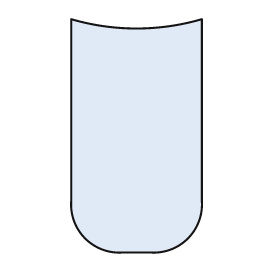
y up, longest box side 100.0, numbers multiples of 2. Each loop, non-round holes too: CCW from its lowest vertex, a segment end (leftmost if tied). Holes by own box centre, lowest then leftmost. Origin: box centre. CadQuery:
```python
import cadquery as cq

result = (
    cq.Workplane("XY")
    .moveTo(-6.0, -50.0)
    .lineTo(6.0, -50.0)
    .threePointArc((22.0, -44.0), (28.0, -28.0))
    .lineTo(28.0, 50.0)
    .threePointArc((0.0, 46.0), (-28.0, 50.0))
    .lineTo(-28.0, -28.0)
    .threePointArc((-22.0, -44.0), (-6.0, -50.0))
    .close()
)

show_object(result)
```